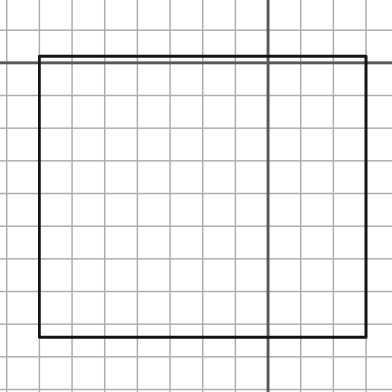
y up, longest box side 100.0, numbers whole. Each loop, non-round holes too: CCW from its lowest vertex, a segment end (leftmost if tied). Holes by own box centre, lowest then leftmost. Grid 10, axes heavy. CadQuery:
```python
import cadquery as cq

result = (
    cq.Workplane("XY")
    .moveTo(-70.0, -84.0)
    .lineTo(30.0, -84.0)
    .lineTo(30.0, 2.0)
    .lineTo(-70.0, 2.0)
    .close()
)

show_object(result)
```